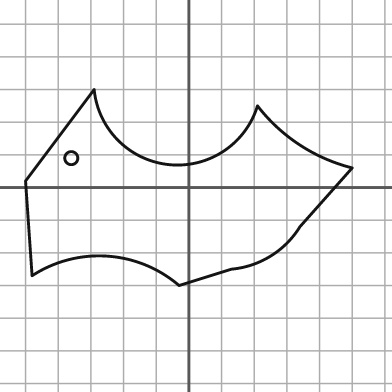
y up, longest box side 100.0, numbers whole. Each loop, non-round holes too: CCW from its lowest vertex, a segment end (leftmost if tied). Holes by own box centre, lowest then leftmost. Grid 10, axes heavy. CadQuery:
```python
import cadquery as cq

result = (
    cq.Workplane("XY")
    .moveTo(-3.0, -30.0)
    .lineTo(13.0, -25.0)
    .threePointArc((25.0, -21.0), (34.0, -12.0))
    .lineTo(50.0, 6.0)
    .threePointArc((34.0, 13.0), (21.0, 25.0))
    .threePointArc((-6.0, 7.0), (-29.0, 30.0))
    .lineTo(-50.0, 2.0)
    .lineTo(-48.0, -27.0)
    .threePointArc((-25.0, -21.0), (-3.0, -30.0))
    .close()
    .moveTo(-36.0, 9.0)
    .circle(2.0)
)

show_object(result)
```